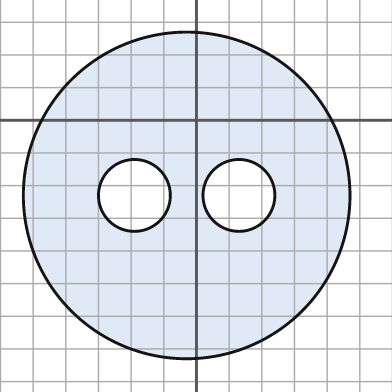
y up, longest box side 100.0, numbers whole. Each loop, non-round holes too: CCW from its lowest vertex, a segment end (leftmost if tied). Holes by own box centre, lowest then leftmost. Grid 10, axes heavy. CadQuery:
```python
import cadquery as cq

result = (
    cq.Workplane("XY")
    .moveTo(-3.0, -23.0)
    .circle(50.0)
    .moveTo(-19.0, -23.0)
    .circle(11.0)
    .moveTo(13.0, -23.0)
    .circle(11.0)
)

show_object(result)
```